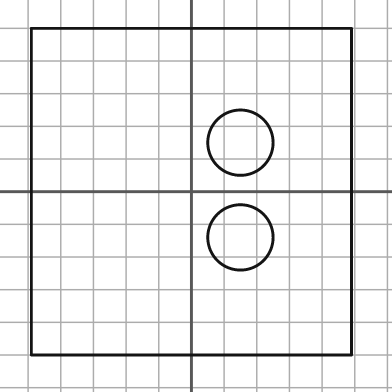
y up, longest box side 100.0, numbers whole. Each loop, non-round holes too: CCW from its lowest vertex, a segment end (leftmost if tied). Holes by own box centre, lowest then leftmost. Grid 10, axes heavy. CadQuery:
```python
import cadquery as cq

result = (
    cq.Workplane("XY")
    .moveTo(-49.0, -50.0)
    .lineTo(49.0, -50.0)
    .lineTo(49.0, 50.0)
    .lineTo(-49.0, 50.0)
    .close()
    .moveTo(15.0, -14.0)
    .circle(10.0)
    .moveTo(15.0, 15.0)
    .circle(10.0)
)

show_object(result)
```